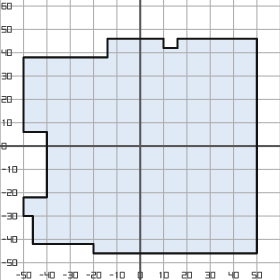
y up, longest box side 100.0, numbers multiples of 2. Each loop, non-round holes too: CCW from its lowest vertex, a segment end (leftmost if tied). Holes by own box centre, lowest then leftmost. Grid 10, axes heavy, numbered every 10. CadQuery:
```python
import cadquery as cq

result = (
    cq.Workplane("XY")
    .moveTo(-20.0, -46.0)
    .lineTo(50.0, -46.0)
    .lineTo(50.0, 46.0)
    .lineTo(16.0, 46.0)
    .lineTo(16.0, 42.0)
    .lineTo(10.0, 42.0)
    .lineTo(10.0, 46.0)
    .lineTo(-14.0, 46.0)
    .lineTo(-14.0, 38.0)
    .lineTo(-50.0, 38.0)
    .lineTo(-50.0, 6.0)
    .lineTo(-40.0, 6.0)
    .lineTo(-40.0, -22.0)
    .lineTo(-50.0, -22.0)
    .lineTo(-50.0, -30.0)
    .lineTo(-46.0, -30.0)
    .lineTo(-46.0, -42.0)
    .lineTo(-20.0, -42.0)
    .close()
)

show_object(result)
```